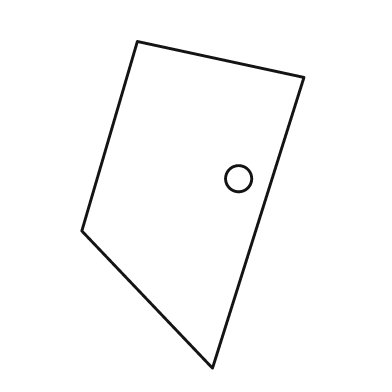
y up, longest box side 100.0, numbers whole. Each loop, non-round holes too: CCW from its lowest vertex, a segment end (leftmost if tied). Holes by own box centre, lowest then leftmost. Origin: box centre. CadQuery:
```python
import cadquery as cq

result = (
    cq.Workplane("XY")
    .moveTo(6.0, -50.0)
    .lineTo(34.0, 39.0)
    .lineTo(-17.0, 50.0)
    .lineTo(-34.0, -8.0)
    .close()
    .moveTo(14.0, 8.0)
    .circle(4.0)
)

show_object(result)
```